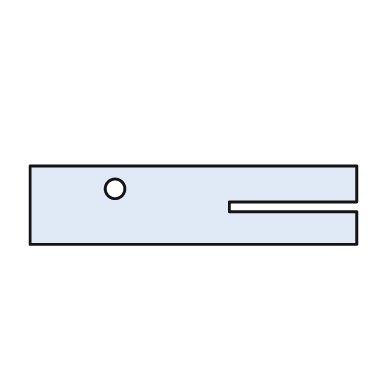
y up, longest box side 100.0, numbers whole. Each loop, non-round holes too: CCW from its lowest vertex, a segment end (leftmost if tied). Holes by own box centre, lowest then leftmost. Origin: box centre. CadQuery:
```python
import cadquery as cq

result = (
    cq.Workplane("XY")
    .moveTo(-50.0, -12.0)
    .lineTo(50.0, -12.0)
    .lineTo(50.0, -2.0)
    .lineTo(11.0, -2.0)
    .lineTo(11.0, 1.0)
    .lineTo(50.0, 1.0)
    .lineTo(50.0, 12.0)
    .lineTo(-50.0, 12.0)
    .close()
    .moveTo(-24.0, 5.0)
    .circle(3.0)
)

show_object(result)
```